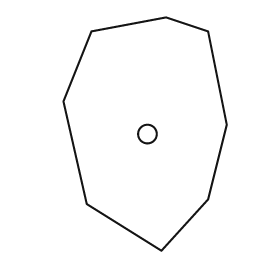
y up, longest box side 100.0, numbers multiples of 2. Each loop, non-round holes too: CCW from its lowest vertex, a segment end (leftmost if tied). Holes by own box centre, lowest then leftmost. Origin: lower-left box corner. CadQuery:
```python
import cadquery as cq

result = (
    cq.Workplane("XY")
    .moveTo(42.0, 0.0)
    .lineTo(62.0, 22.0)
    .lineTo(70.0, 54.0)
    .lineTo(62.0, 94.0)
    .lineTo(44.0, 100.0)
    .lineTo(12.0, 94.0)
    .lineTo(0.0, 64.0)
    .lineTo(10.0, 20.0)
    .close()
    .moveTo(36.0, 50.0)
    .circle(4.0)
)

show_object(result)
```